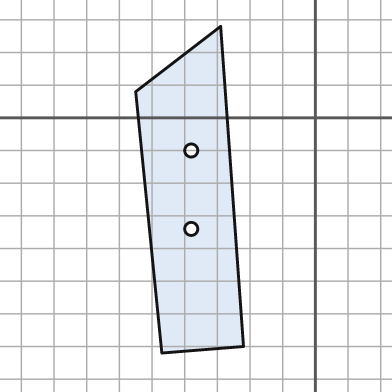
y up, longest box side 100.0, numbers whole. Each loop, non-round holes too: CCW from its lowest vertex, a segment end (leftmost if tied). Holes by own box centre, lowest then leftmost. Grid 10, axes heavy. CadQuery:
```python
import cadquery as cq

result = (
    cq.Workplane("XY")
    .moveTo(-47.0, -72.0)
    .lineTo(-22.0, -70.0)
    .lineTo(-29.0, 28.0)
    .lineTo(-55.0, 8.0)
    .close()
    .moveTo(-38.0, -34.0)
    .circle(2.0)
    .moveTo(-38.0, -10.0)
    .circle(2.0)
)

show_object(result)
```